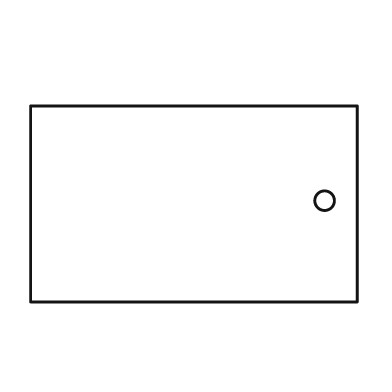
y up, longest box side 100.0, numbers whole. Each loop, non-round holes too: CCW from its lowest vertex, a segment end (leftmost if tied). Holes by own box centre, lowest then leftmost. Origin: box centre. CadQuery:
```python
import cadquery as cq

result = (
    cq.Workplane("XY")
    .moveTo(-50.0, -30.0)
    .lineTo(50.0, -30.0)
    .lineTo(50.0, 30.0)
    .lineTo(-50.0, 30.0)
    .close()
    .moveTo(40.0, 1.0)
    .circle(3.0)
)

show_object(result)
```